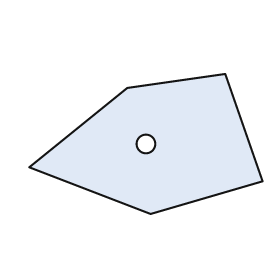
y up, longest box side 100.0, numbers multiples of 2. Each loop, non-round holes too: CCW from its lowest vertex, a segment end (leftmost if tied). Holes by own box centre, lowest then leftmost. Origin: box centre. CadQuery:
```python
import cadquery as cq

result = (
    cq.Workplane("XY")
    .moveTo(2.0, -30.0)
    .lineTo(50.0, -16.0)
    .lineTo(34.0, 30.0)
    .lineTo(-8.0, 24.0)
    .lineTo(-50.0, -10.0)
    .close()
    .moveTo(0.0, 0.0)
    .circle(4.0)
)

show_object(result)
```